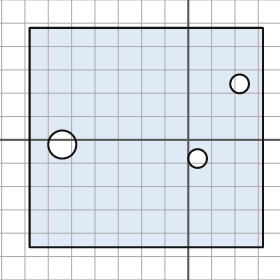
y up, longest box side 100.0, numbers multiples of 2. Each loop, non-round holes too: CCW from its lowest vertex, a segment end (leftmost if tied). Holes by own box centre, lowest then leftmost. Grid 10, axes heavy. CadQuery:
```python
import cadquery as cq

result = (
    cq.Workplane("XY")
    .moveTo(-68.0, -46.0)
    .lineTo(32.0, -46.0)
    .lineTo(32.0, 48.0)
    .lineTo(-68.0, 48.0)
    .close()
    .moveTo(4.0, -8.0)
    .circle(4.0)
    .moveTo(-54.0, -2.0)
    .circle(6.0)
    .moveTo(22.0, 24.0)
    .circle(4.0)
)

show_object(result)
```